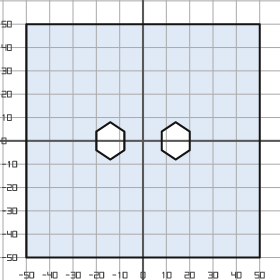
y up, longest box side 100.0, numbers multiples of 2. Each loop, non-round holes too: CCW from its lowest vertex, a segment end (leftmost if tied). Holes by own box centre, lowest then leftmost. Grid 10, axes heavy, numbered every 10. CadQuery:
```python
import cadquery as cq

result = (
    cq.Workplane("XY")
    .moveTo(-50.0, -50.0)
    .lineTo(50.0, -50.0)
    .lineTo(50.0, 50.0)
    .lineTo(-50.0, 50.0)
    .close()
    .moveTo(-14.0, -8.0)
    .lineTo(-8.0, -4.0)
    .lineTo(-8.0, 4.0)
    .lineTo(-14.0, 8.0)
    .lineTo(-20.0, 4.0)
    .lineTo(-20.0, -4.0)
    .close()
    .moveTo(14.0, -8.0)
    .lineTo(20.0, -4.0)
    .lineTo(20.0, 4.0)
    .lineTo(14.0, 8.0)
    .lineTo(8.0, 4.0)
    .lineTo(8.0, -4.0)
    .close()
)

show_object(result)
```